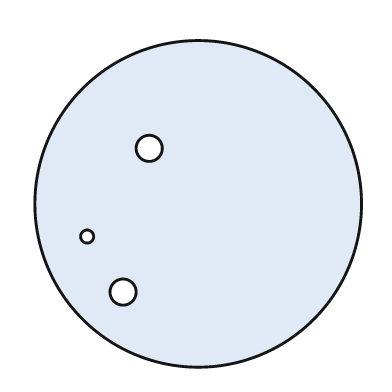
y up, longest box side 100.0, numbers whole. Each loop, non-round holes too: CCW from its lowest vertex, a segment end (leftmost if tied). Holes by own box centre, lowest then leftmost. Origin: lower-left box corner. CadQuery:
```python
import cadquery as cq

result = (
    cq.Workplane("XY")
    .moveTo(50.0, 50.0)
    .circle(50.0)
    .moveTo(27.0, 23.0)
    .circle(4.0)
    .moveTo(16.0, 40.0)
    .circle(2.0)
    .moveTo(35.0, 67.0)
    .circle(4.0)
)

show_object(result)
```